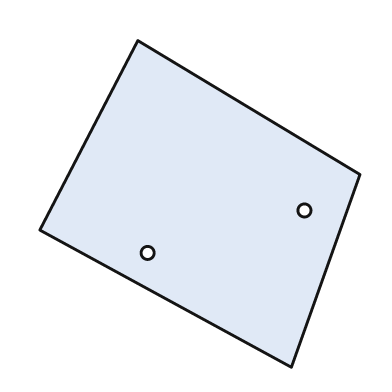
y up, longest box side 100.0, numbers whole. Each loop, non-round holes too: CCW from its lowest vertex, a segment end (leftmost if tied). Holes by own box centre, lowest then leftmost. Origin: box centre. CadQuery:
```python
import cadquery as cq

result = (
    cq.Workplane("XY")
    .moveTo(28.0, -50.0)
    .lineTo(49.0, 9.0)
    .lineTo(-19.0, 50.0)
    .lineTo(-49.0, -8.0)
    .close()
    .moveTo(-16.0, -15.0)
    .circle(2.0)
    .moveTo(32.0, -2.0)
    .circle(2.0)
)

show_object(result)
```